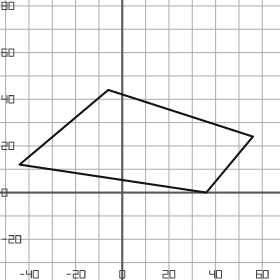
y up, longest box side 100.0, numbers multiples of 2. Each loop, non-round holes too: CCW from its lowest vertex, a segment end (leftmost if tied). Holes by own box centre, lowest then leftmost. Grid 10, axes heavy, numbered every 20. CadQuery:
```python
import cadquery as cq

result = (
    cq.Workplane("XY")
    .moveTo(36.0, 0.0)
    .lineTo(56.0, 24.0)
    .lineTo(-6.0, 44.0)
    .lineTo(-44.0, 12.0)
    .close()
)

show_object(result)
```